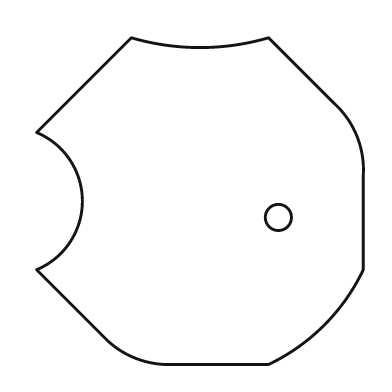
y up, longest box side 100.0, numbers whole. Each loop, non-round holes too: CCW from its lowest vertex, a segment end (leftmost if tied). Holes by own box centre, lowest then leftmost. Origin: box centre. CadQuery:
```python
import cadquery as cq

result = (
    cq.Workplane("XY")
    .moveTo(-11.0, -50.0)
    .lineTo(21.0, -50.0)
    .threePointArc((38.0, -38.0), (50.0, -21.0))
    .lineTo(50.0, 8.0)
    .threePointArc((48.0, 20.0), (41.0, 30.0))
    .lineTo(21.0, 50.0)
    .threePointArc((0.0, 47.0), (-21.0, 50.0))
    .lineTo(-50.0, 21.0)
    .threePointArc((-36.0, 0.0), (-50.0, -21.0))
    .lineTo(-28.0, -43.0)
    .threePointArc((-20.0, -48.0), (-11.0, -50.0))
    .close()
    .moveTo(24.0, -5.0)
    .circle(4.0)
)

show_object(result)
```